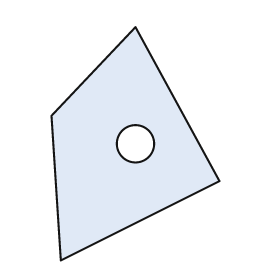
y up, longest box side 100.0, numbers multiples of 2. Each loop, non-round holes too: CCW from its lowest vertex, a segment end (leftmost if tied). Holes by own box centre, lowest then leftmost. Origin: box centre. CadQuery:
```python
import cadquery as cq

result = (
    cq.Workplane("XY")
    .moveTo(-32.0, -50.0)
    .lineTo(36.0, -16.0)
    .lineTo(0.0, 50.0)
    .lineTo(-36.0, 12.0)
    .close()
    .moveTo(0.0, 0.0)
    .circle(8.0)
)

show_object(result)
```